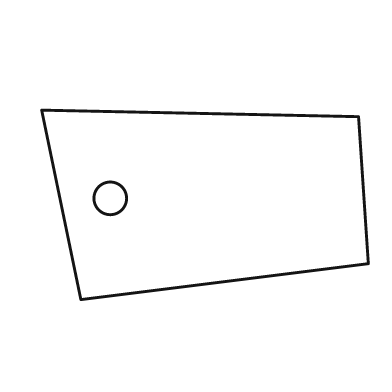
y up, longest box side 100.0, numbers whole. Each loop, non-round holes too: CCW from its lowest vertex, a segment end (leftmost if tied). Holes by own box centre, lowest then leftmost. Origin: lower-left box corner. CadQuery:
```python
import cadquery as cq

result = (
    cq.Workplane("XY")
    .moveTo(12.0, 0.0)
    .lineTo(100.0, 11.0)
    .lineTo(97.0, 56.0)
    .lineTo(0.0, 58.0)
    .close()
    .moveTo(21.0, 31.0)
    .circle(5.0)
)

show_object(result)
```